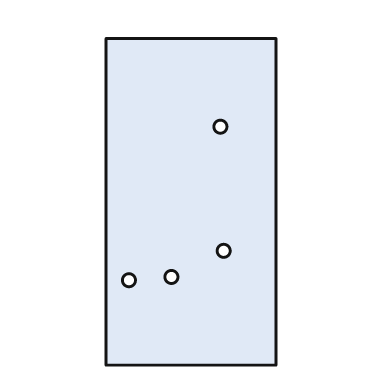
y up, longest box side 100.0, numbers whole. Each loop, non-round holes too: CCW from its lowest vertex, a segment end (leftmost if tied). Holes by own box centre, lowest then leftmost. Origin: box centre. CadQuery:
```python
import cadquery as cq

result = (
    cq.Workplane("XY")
    .moveTo(-26.0, -50.0)
    .lineTo(26.0, -50.0)
    .lineTo(26.0, 50.0)
    .lineTo(-26.0, 50.0)
    .close()
    .moveTo(-19.0, -24.0)
    .circle(2.0)
    .moveTo(-6.0, -23.0)
    .circle(2.0)
    .moveTo(10.0, -15.0)
    .circle(2.0)
    .moveTo(9.0, 23.0)
    .circle(2.0)
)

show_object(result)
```